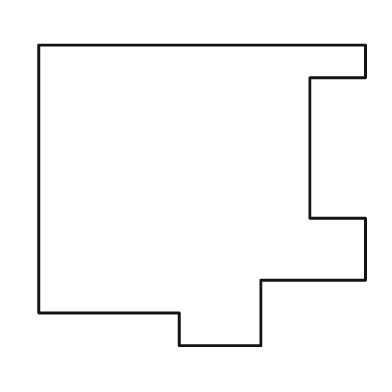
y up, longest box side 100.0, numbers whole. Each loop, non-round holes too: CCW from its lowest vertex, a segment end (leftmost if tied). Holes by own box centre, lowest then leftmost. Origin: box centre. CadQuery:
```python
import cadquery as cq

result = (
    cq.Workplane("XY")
    .moveTo(-7.0, -46.0)
    .lineTo(18.0, -46.0)
    .lineTo(18.0, -26.0)
    .lineTo(50.0, -26.0)
    .lineTo(50.0, -7.0)
    .lineTo(33.0, -7.0)
    .lineTo(33.0, 36.0)
    .lineTo(50.0, 36.0)
    .lineTo(50.0, 46.0)
    .lineTo(-50.0, 46.0)
    .lineTo(-50.0, -36.0)
    .lineTo(-7.0, -36.0)
    .close()
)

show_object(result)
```